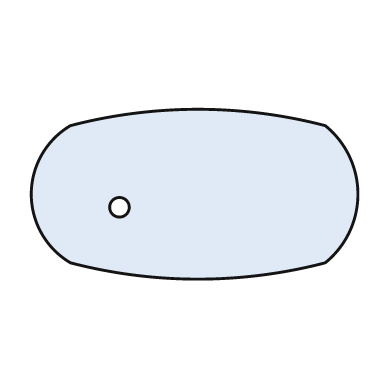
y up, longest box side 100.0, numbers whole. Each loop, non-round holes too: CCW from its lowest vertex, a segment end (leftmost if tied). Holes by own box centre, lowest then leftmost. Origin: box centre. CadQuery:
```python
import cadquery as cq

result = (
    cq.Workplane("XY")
    .moveTo(-38.0, -21.0)
    .threePointArc((1.0, -26.0), (40.0, -21.0))
    .threePointArc((50.0, 0.0), (40.0, 21.0))
    .threePointArc((1.0, 26.0), (-38.0, 21.0))
    .threePointArc((-50.0, 0.0), (-38.0, -21.0))
    .close()
    .moveTo(-23.0, -4.0)
    .circle(3.0)
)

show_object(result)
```